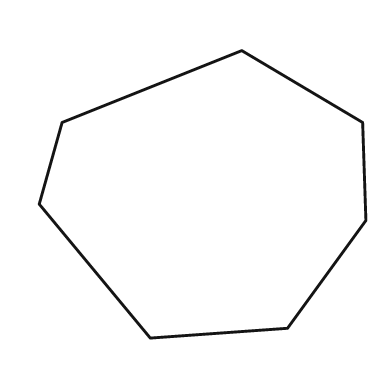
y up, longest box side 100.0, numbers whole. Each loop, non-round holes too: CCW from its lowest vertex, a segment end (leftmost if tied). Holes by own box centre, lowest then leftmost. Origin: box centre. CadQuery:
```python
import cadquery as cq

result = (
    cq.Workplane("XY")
    .moveTo(-16.0, -44.0)
    .lineTo(26.0, -41.0)
    .lineTo(50.0, -8.0)
    .lineTo(49.0, 22.0)
    .lineTo(12.0, 44.0)
    .lineTo(-43.0, 22.0)
    .lineTo(-50.0, -3.0)
    .close()
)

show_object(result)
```